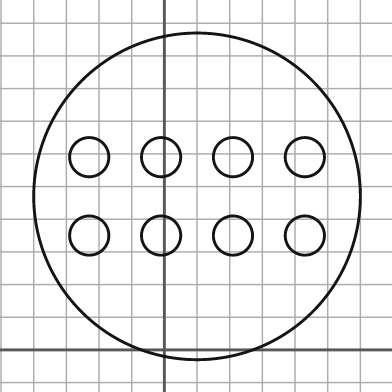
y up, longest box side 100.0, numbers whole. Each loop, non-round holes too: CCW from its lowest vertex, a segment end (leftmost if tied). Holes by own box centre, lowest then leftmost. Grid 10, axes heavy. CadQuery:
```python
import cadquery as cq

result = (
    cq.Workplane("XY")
    .moveTo(10.0, 47.0)
    .circle(50.0)
    .moveTo(-23.0, 35.0)
    .circle(6.0)
    .moveTo(-1.0, 35.0)
    .circle(6.0)
    .moveTo(21.0, 35.0)
    .circle(6.0)
    .moveTo(43.0, 35.0)
    .circle(6.0)
    .moveTo(-23.0, 59.0)
    .circle(6.0)
    .moveTo(-1.0, 59.0)
    .circle(6.0)
    .moveTo(21.0, 59.0)
    .circle(6.0)
    .moveTo(43.0, 59.0)
    .circle(6.0)
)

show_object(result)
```